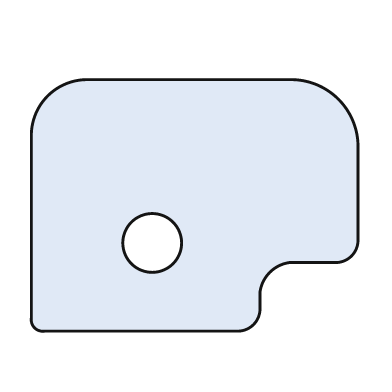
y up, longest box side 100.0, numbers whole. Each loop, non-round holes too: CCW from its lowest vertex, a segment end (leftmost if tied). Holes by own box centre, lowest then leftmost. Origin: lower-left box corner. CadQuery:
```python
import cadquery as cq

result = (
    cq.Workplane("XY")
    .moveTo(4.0, 0.0)
    .lineTo(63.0, 0.0)
    .threePointArc((68.0, 2.0), (70.0, 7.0))
    .lineTo(70.0, 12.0)
    .threePointArc((73.0, 18.0), (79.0, 21.0))
    .lineTo(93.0, 21.0)
    .threePointArc((98.0, 23.0), (100.0, 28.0))
    .lineTo(100.0, 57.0)
    .threePointArc((94.0, 71.0), (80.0, 77.0))
    .lineTo(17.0, 77.0)
    .threePointArc((5.0, 72.0), (0.0, 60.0))
    .lineTo(0.0, 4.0)
    .threePointArc((1.0, 1.0), (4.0, 0.0))
    .close()
    .moveTo(37.0, 27.0)
    .circle(9.0)
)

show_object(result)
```